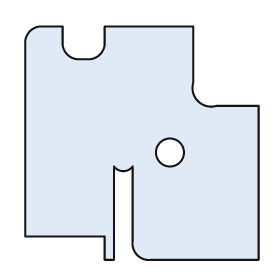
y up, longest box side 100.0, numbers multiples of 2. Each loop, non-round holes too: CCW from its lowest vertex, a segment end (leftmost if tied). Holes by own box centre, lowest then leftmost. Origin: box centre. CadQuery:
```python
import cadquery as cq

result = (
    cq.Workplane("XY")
    .moveTo(-16.0, -50.0)
    .lineTo(-12.0, -50.0)
    .lineTo(-12.0, -10.0)
    .threePointArc((-8.0, -12.0), (-4.0, -10.0))
    .lineTo(-4.0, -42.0)
    .threePointArc((-2.0, -48.0), (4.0, -50.0))
    .lineTo(50.0, -50.0)
    .lineTo(50.0, 16.0)
    .lineTo(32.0, 16.0)
    .threePointArc((24.0, 18.0), (22.0, 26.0))
    .lineTo(22.0, 50.0)
    .lineTo(-16.0, 50.0)
    .lineTo(-16.0, 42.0)
    .threePointArc((-18.0, 38.0), (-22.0, 36.0))
    .lineTo(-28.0, 36.0)
    .threePointArc((-32.0, 38.0), (-34.0, 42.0))
    .lineTo(-34.0, 50.0)
    .lineTo(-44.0, 50.0)
    .threePointArc((-48.0, 48.0), (-50.0, 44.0))
    .lineTo(-50.0, -40.0)
    .lineTo(-16.0, -40.0)
    .close()
    .moveTo(12.0, -4.0)
    .circle(6.0)
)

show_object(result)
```